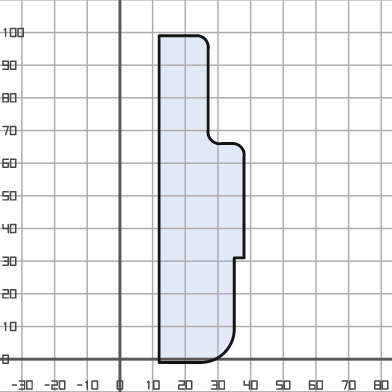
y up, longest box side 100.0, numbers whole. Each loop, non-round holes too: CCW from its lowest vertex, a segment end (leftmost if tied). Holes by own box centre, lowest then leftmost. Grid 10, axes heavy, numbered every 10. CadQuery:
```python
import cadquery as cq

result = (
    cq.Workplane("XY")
    .moveTo(12.0, -1.0)
    .lineTo(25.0, -1.0)
    .threePointArc((32.0, 2.0), (35.0, 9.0))
    .lineTo(35.0, 31.0)
    .lineTo(38.0, 31.0)
    .lineTo(38.0, 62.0)
    .threePointArc((37.0, 65.0), (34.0, 66.0))
    .lineTo(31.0, 66.0)
    .threePointArc((28.0, 67.0), (27.0, 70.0))
    .lineTo(27.0, 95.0)
    .threePointArc((26.0, 98.0), (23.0, 99.0))
    .lineTo(12.0, 99.0)
    .close()
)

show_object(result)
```